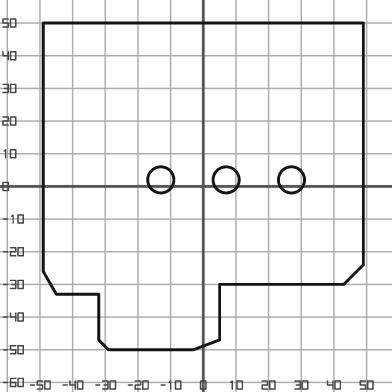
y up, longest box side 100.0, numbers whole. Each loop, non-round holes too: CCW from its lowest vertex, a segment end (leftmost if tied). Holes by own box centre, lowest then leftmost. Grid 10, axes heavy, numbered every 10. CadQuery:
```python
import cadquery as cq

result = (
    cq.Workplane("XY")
    .moveTo(-29.0, -50.0)
    .lineTo(-3.0, -50.0)
    .lineTo(5.0, -47.0)
    .lineTo(5.0, -30.0)
    .lineTo(43.0, -30.0)
    .lineTo(49.0, -24.0)
    .lineTo(49.0, 50.0)
    .lineTo(-49.0, 50.0)
    .lineTo(-49.0, -26.0)
    .lineTo(-45.0, -33.0)
    .lineTo(-32.0, -33.0)
    .lineTo(-32.0, -47.0)
    .close()
    .moveTo(-13.0, 2.0)
    .circle(4.0)
    .moveTo(7.0, 2.0)
    .circle(4.0)
    .moveTo(27.0, 2.0)
    .circle(4.0)
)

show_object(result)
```